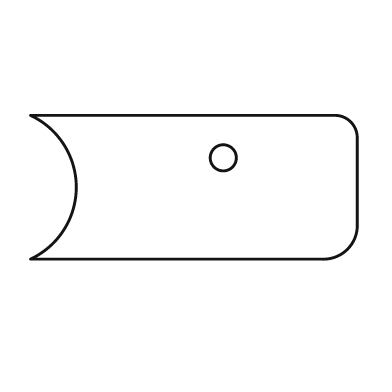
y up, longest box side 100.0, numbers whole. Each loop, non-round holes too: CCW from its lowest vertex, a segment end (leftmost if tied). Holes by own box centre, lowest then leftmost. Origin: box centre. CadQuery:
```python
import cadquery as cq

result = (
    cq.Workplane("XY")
    .moveTo(-50.0, -22.0)
    .lineTo(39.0, -22.0)
    .threePointArc((47.0, -19.0), (50.0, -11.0))
    .lineTo(50.0, 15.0)
    .threePointArc((48.0, 20.0), (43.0, 22.0))
    .lineTo(-50.0, 22.0)
    .threePointArc((-36.0, 0.0), (-50.0, -22.0))
    .close()
    .moveTo(9.0, 9.0)
    .circle(4.0)
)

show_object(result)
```